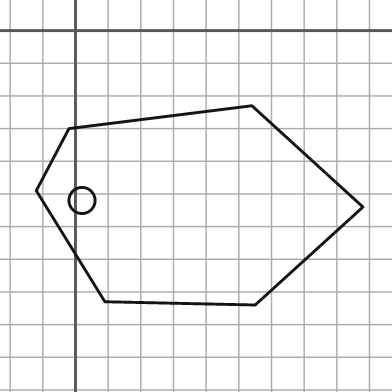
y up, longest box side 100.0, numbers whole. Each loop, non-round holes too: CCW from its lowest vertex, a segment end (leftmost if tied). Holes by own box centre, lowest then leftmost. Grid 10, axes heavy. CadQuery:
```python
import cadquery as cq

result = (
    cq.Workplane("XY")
    .moveTo(55.0, -84.0)
    .lineTo(88.0, -54.0)
    .lineTo(54.0, -23.0)
    .lineTo(-2.0, -30.0)
    .lineTo(-12.0, -49.0)
    .lineTo(9.0, -83.0)
    .close()
    .moveTo(2.0, -52.0)
    .circle(4.0)
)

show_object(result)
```